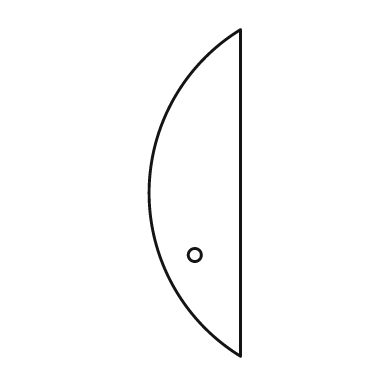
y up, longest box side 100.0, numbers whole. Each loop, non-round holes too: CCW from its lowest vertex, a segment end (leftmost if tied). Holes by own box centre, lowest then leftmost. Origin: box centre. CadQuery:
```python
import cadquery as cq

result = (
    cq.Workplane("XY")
    .moveTo(14.0, -50.0)
    .lineTo(14.0, 50.0)
    .threePointArc((-14.0, 0.0), (14.0, -50.0))
    .close()
    .moveTo(0.0, -19.0)
    .circle(2.0)
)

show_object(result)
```